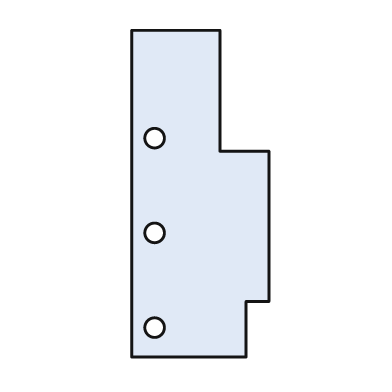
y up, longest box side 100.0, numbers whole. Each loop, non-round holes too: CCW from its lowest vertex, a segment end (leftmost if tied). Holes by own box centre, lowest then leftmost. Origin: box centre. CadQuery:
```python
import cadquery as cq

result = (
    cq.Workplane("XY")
    .moveTo(-21.0, -50.0)
    .lineTo(14.0, -50.0)
    .lineTo(14.0, -33.0)
    .lineTo(21.0, -33.0)
    .lineTo(21.0, 13.0)
    .lineTo(6.0, 13.0)
    .lineTo(6.0, 50.0)
    .lineTo(-21.0, 50.0)
    .close()
    .moveTo(-14.0, -41.0)
    .circle(3.0)
    .moveTo(-14.0, -12.0)
    .circle(3.0)
    .moveTo(-14.0, 17.0)
    .circle(3.0)
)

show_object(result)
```